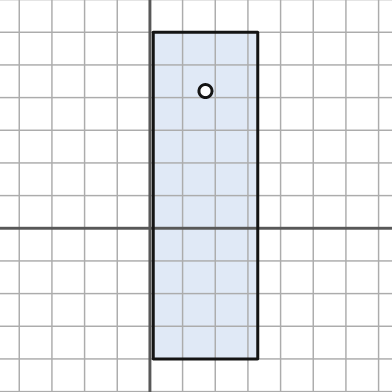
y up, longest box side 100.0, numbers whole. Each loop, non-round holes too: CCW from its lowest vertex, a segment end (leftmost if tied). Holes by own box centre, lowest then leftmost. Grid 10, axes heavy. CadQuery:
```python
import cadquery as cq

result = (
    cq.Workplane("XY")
    .moveTo(1.0, -40.0)
    .lineTo(33.0, -40.0)
    .lineTo(33.0, 60.0)
    .lineTo(1.0, 60.0)
    .close()
    .moveTo(17.0, 42.0)
    .circle(2.0)
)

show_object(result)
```